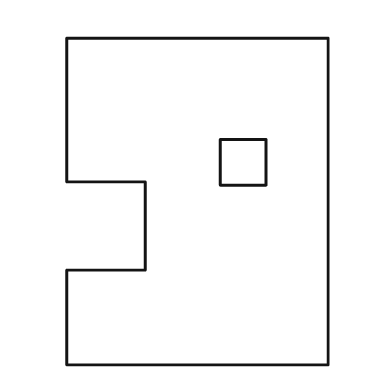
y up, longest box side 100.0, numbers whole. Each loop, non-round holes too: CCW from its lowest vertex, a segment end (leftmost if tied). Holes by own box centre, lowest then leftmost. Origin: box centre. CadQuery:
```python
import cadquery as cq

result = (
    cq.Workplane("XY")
    .moveTo(-40.0, -50.0)
    .lineTo(40.0, -50.0)
    .lineTo(40.0, 50.0)
    .lineTo(-40.0, 50.0)
    .lineTo(-40.0, 6.0)
    .lineTo(-16.0, 6.0)
    .lineTo(-16.0, -21.0)
    .lineTo(-40.0, -21.0)
    .close()
    .moveTo(7.0, 5.0)
    .lineTo(21.0, 5.0)
    .lineTo(21.0, 19.0)
    .lineTo(7.0, 19.0)
    .close()
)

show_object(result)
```